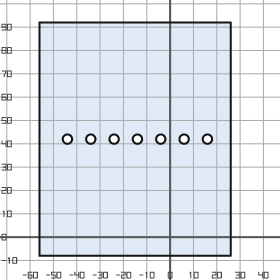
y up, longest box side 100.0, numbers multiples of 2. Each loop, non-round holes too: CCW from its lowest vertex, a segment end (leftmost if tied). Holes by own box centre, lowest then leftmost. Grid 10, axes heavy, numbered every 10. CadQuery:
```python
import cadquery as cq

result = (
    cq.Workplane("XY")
    .moveTo(-56.0, -8.0)
    .lineTo(26.0, -8.0)
    .lineTo(26.0, 92.0)
    .lineTo(-56.0, 92.0)
    .close()
    .moveTo(-44.0, 42.0)
    .circle(2.0)
    .moveTo(-34.0, 42.0)
    .circle(2.0)
    .moveTo(-24.0, 42.0)
    .circle(2.0)
    .moveTo(-14.0, 42.0)
    .circle(2.0)
    .moveTo(-4.0, 42.0)
    .circle(2.0)
    .moveTo(6.0, 42.0)
    .circle(2.0)
    .moveTo(16.0, 42.0)
    .circle(2.0)
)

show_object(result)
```